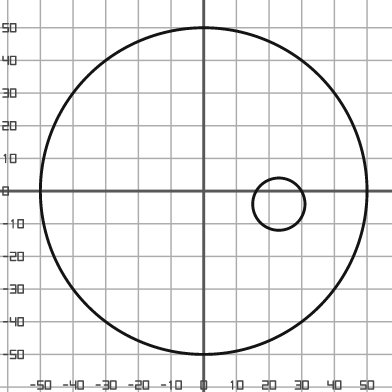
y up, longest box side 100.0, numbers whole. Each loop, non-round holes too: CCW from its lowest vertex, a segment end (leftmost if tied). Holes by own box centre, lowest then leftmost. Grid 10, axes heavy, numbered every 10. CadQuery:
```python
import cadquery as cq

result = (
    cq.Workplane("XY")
    .moveTo(0.0, 0.0)
    .circle(50.0)
    .moveTo(23.0, -4.0)
    .circle(8.0)
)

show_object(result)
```